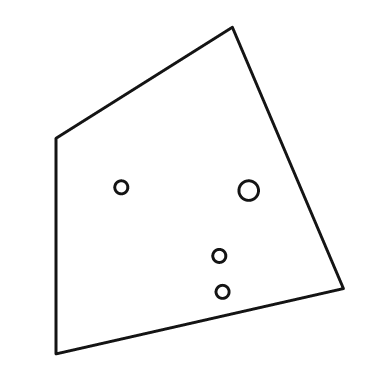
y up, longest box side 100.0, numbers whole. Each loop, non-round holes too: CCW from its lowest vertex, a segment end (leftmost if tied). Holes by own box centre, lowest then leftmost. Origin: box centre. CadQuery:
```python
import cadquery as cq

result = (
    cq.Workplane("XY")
    .moveTo(-44.0, -50.0)
    .lineTo(44.0, -30.0)
    .lineTo(10.0, 50.0)
    .lineTo(-44.0, 16.0)
    .close()
    .moveTo(7.0, -31.0)
    .circle(2.0)
    .moveTo(6.0, -20.0)
    .circle(2.0)
    .moveTo(15.0, 0.0)
    .circle(3.0)
    .moveTo(-24.0, 1.0)
    .circle(2.0)
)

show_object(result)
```